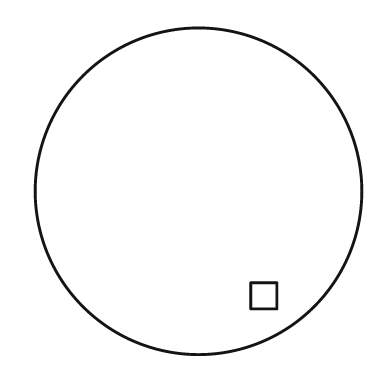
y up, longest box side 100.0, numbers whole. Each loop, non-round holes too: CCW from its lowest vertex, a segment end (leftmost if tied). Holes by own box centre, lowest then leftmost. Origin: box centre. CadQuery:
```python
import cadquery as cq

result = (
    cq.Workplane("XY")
    .moveTo(0.0, 0.0)
    .circle(50.0)
    .moveTo(16.0, -36.0)
    .lineTo(24.0, -36.0)
    .lineTo(24.0, -28.0)
    .lineTo(16.0, -28.0)
    .close()
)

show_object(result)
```